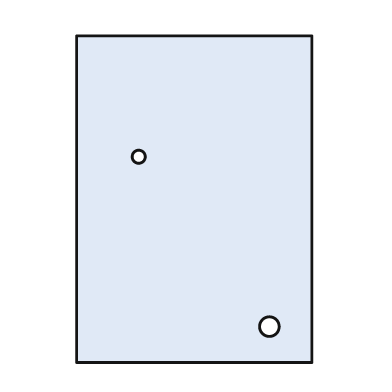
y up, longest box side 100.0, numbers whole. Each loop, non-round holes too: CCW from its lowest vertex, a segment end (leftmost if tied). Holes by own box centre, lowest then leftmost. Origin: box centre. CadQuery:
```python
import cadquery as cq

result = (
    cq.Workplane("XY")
    .moveTo(-36.0, -50.0)
    .lineTo(36.0, -50.0)
    .lineTo(36.0, 50.0)
    .lineTo(-36.0, 50.0)
    .close()
    .moveTo(23.0, -39.0)
    .circle(3.0)
    .moveTo(-17.0, 13.0)
    .circle(2.0)
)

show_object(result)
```